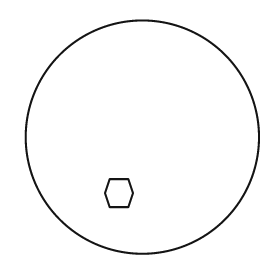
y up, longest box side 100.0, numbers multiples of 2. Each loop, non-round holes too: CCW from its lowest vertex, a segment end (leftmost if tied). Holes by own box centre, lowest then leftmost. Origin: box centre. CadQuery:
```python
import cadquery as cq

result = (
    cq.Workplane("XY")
    .moveTo(0.0, 0.0)
    .circle(50.0)
    .moveTo(-14.0, -30.0)
    .lineTo(-6.0, -30.0)
    .lineTo(-4.0, -24.0)
    .lineTo(-6.0, -18.0)
    .lineTo(-14.0, -18.0)
    .lineTo(-16.0, -24.0)
    .close()
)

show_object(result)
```